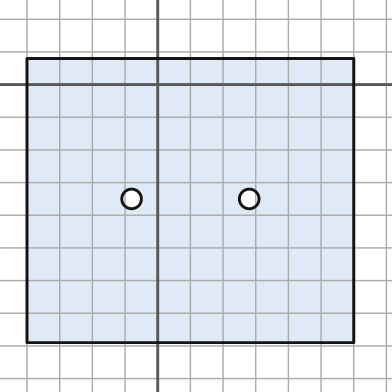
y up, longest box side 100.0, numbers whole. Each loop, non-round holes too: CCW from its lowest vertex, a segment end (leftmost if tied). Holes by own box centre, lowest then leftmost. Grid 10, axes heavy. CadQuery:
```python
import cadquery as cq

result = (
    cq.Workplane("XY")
    .moveTo(-40.0, -79.0)
    .lineTo(60.0, -79.0)
    .lineTo(60.0, 8.0)
    .lineTo(-40.0, 8.0)
    .close()
    .moveTo(-8.0, -35.0)
    .circle(3.0)
    .moveTo(28.0, -35.0)
    .circle(3.0)
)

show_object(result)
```